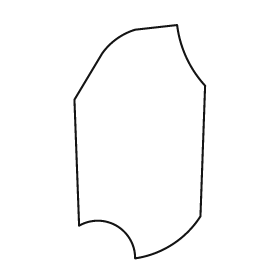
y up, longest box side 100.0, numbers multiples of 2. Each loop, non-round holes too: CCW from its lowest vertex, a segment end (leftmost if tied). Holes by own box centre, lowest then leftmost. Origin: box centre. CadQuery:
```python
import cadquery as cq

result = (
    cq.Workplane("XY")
    .moveTo(-2.0, -50.0)
    .threePointArc((14.0, -44.0), (26.0, -32.0))
    .lineTo(28.0, 24.0)
    .threePointArc((20.0, 36.0), (16.0, 50.0))
    .lineTo(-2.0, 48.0)
    .threePointArc((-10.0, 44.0), (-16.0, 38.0))
    .lineTo(-28.0, 18.0)
    .lineTo(-26.0, -36.0)
    .threePointArc((-10.0, -36.0), (-2.0, -50.0))
    .close()
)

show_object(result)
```